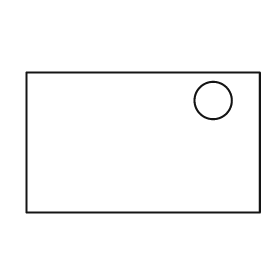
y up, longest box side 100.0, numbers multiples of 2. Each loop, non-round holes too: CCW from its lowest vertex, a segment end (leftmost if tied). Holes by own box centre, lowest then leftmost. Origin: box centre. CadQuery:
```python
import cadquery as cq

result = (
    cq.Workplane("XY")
    .moveTo(-50.0, -30.0)
    .lineTo(50.0, -30.0)
    .lineTo(50.0, 30.0)
    .lineTo(-50.0, 30.0)
    .close()
    .moveTo(30.0, 18.0)
    .circle(8.0)
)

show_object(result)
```